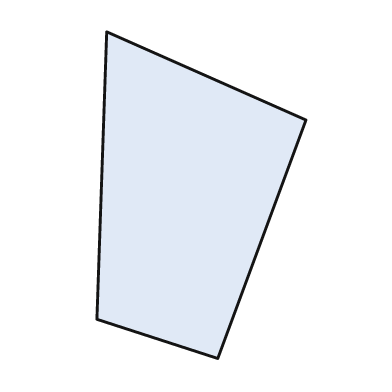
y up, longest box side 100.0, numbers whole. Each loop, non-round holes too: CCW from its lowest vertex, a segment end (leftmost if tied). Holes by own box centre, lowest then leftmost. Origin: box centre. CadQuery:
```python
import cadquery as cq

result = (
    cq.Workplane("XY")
    .moveTo(5.0, -50.0)
    .lineTo(32.0, 23.0)
    .lineTo(-29.0, 50.0)
    .lineTo(-32.0, -38.0)
    .close()
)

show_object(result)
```